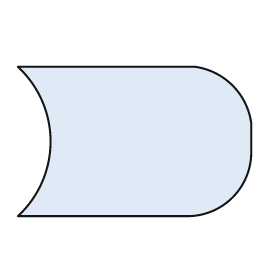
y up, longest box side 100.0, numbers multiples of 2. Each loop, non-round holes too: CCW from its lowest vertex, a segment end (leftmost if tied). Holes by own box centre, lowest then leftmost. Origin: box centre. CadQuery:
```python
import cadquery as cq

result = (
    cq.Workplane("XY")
    .moveTo(-50.0, -32.0)
    .lineTo(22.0, -32.0)
    .threePointArc((42.0, -24.0), (50.0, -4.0))
    .lineTo(50.0, 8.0)
    .threePointArc((42.0, 24.0), (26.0, 32.0))
    .lineTo(-50.0, 32.0)
    .threePointArc((-36.0, 0.0), (-50.0, -32.0))
    .close()
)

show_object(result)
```